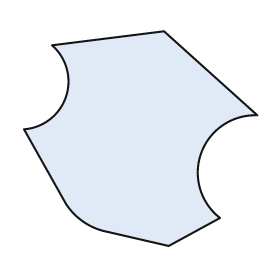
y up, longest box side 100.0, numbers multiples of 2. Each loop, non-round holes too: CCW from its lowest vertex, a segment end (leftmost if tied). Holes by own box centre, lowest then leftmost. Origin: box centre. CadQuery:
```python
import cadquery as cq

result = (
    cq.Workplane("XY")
    .moveTo(12.0, -46.0)
    .lineTo(34.0, -34.0)
    .threePointArc((26.0, -6.0), (50.0, 10.0))
    .lineTo(10.0, 46.0)
    .lineTo(-38.0, 40.0)
    .threePointArc((-32.0, 18.0), (-50.0, 4.0))
    .lineTo(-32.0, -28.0)
    .threePointArc((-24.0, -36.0), (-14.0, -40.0))
    .close()
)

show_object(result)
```